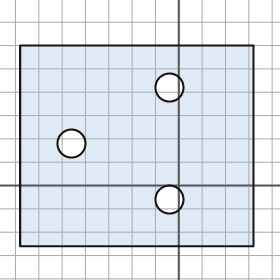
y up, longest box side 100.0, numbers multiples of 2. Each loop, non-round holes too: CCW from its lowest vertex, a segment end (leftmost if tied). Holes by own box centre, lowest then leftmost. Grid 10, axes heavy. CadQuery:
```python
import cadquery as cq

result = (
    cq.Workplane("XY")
    .moveTo(-68.0, -26.0)
    .lineTo(32.0, -26.0)
    .lineTo(32.0, 60.0)
    .lineTo(-68.0, 60.0)
    .close()
    .moveTo(-4.0, -6.0)
    .circle(6.0)
    .moveTo(-46.0, 18.0)
    .circle(6.0)
    .moveTo(-4.0, 42.0)
    .circle(6.0)
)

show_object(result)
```